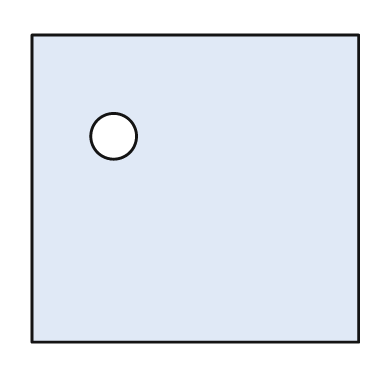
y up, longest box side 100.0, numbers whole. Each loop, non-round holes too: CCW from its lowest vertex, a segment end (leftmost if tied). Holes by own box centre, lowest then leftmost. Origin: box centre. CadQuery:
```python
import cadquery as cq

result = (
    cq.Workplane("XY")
    .moveTo(-50.0, -47.0)
    .lineTo(50.0, -47.0)
    .lineTo(50.0, 47.0)
    .lineTo(-50.0, 47.0)
    .close()
    .moveTo(-25.0, 16.0)
    .circle(7.0)
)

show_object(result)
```